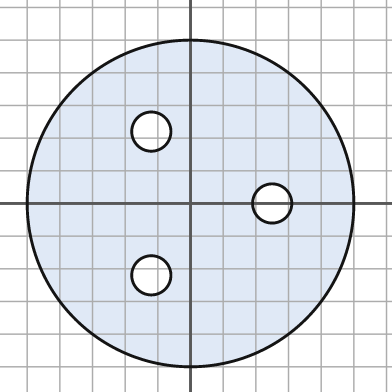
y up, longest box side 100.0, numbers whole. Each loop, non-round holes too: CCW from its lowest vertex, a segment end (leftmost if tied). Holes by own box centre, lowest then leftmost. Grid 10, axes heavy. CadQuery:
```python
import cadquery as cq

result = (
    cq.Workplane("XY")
    .moveTo(0.0, 0.0)
    .circle(50.0)
    .moveTo(-12.0, -22.0)
    .circle(6.0)
    .moveTo(25.0, 0.0)
    .circle(6.0)
    .moveTo(-12.0, 22.0)
    .circle(6.0)
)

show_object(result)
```